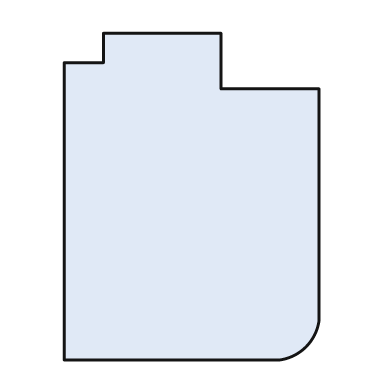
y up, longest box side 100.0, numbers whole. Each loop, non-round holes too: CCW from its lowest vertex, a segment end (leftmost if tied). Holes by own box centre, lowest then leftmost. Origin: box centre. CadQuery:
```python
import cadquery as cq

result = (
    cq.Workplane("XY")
    .moveTo(-39.0, -50.0)
    .lineTo(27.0, -50.0)
    .threePointArc((35.0, -46.0), (39.0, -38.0))
    .lineTo(39.0, 33.0)
    .lineTo(9.0, 33.0)
    .lineTo(9.0, 50.0)
    .lineTo(-27.0, 50.0)
    .lineTo(-27.0, 41.0)
    .lineTo(-39.0, 41.0)
    .close()
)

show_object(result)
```